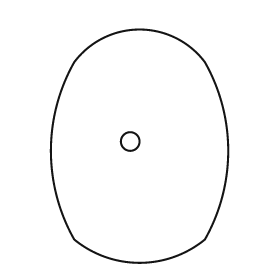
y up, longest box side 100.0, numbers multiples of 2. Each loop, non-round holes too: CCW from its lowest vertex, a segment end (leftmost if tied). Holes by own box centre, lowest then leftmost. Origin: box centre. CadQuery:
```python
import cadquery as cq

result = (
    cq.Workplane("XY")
    .moveTo(-28.0, -40.0)
    .threePointArc((0.0, -50.0), (28.0, -40.0))
    .threePointArc((38.0, -2.0), (28.0, 36.0))
    .threePointArc((0.0, 50.0), (-28.0, 36.0))
    .threePointArc((-38.0, -2.0), (-28.0, -40.0))
    .close()
    .moveTo(-4.0, 2.0)
    .circle(4.0)
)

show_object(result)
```